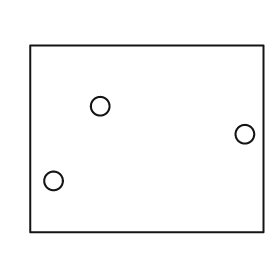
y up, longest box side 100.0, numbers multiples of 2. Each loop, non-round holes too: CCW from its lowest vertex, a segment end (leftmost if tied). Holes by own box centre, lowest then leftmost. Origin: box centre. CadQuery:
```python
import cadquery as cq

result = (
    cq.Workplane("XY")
    .moveTo(-50.0, -40.0)
    .lineTo(50.0, -40.0)
    .lineTo(50.0, 40.0)
    .lineTo(-50.0, 40.0)
    .close()
    .moveTo(-40.0, -18.0)
    .circle(4.0)
    .moveTo(42.0, 2.0)
    .circle(4.0)
    .moveTo(-20.0, 14.0)
    .circle(4.0)
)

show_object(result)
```